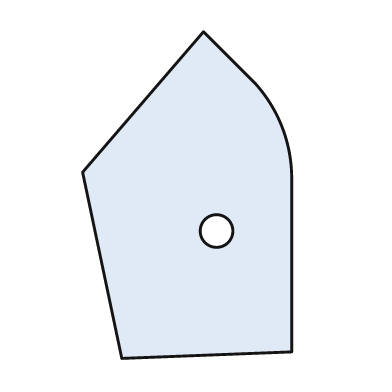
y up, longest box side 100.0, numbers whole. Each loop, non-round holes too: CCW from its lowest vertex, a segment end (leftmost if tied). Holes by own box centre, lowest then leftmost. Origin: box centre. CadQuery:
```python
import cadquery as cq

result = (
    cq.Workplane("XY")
    .moveTo(-20.0, -50.0)
    .lineTo(32.0, -48.0)
    .lineTo(32.0, 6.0)
    .threePointArc((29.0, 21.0), (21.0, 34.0))
    .lineTo(5.0, 50.0)
    .lineTo(-32.0, 7.0)
    .close()
    .moveTo(9.0, -11.0)
    .circle(5.0)
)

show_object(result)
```